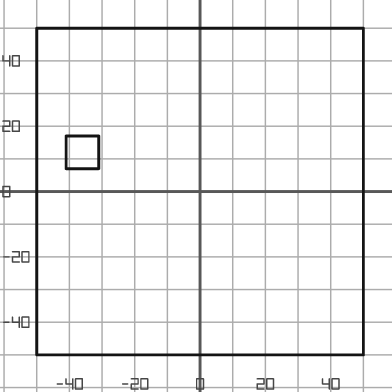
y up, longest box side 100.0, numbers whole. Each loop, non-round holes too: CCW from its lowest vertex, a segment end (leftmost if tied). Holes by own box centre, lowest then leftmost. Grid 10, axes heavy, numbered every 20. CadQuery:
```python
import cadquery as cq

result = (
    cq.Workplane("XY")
    .moveTo(-50.0, -50.0)
    .lineTo(50.0, -50.0)
    .lineTo(50.0, 50.0)
    .lineTo(-50.0, 50.0)
    .close()
    .moveTo(-41.0, 7.0)
    .lineTo(-31.0, 7.0)
    .lineTo(-31.0, 17.0)
    .lineTo(-41.0, 17.0)
    .close()
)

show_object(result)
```